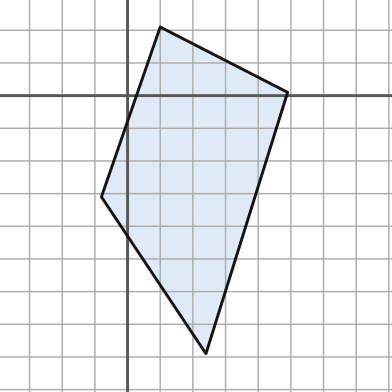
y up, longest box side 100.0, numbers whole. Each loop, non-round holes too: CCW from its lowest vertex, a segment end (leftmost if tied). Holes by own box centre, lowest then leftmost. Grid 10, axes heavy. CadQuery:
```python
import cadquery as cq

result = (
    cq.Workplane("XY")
    .moveTo(24.0, -79.0)
    .lineTo(49.0, 1.0)
    .lineTo(10.0, 21.0)
    .lineTo(-8.0, -31.0)
    .close()
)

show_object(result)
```